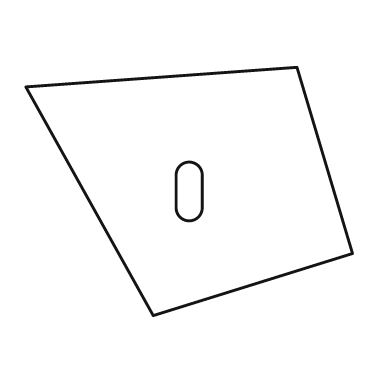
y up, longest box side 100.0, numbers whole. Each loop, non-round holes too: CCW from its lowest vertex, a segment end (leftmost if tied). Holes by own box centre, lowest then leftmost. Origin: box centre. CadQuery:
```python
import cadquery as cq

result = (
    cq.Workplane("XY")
    .moveTo(-11.0, -38.0)
    .lineTo(50.0, -19.0)
    .lineTo(33.0, 38.0)
    .lineTo(-50.0, 32.0)
    .close()
    .moveTo(-4.0, -5.0)
    .threePointArc((0.0, -9.0), (4.0, -5.0))
    .lineTo(4.0, 5.0)
    .threePointArc((0.0, 9.0), (-4.0, 5.0))
    .close()
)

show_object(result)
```